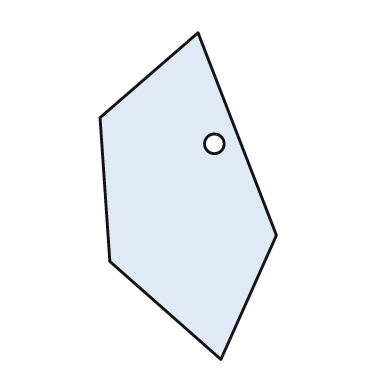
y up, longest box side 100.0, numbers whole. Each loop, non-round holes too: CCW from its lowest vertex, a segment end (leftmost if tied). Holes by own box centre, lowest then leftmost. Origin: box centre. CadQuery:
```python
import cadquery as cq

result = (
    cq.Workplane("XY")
    .moveTo(10.0, -50.0)
    .lineTo(27.0, -12.0)
    .lineTo(3.0, 50.0)
    .lineTo(-27.0, 24.0)
    .lineTo(-24.0, -20.0)
    .close()
    .moveTo(8.0, 16.0)
    .circle(3.0)
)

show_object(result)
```